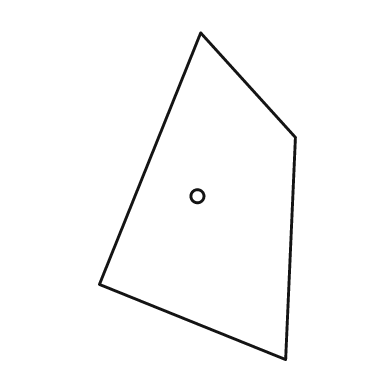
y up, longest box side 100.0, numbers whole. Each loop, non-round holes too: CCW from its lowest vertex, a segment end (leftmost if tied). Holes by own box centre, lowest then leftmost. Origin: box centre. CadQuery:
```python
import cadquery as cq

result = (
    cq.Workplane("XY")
    .moveTo(27.0, -50.0)
    .lineTo(30.0, 18.0)
    .lineTo(1.0, 50.0)
    .lineTo(-30.0, -27.0)
    .close()
    .moveTo(0.0, 0.0)
    .circle(2.0)
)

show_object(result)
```